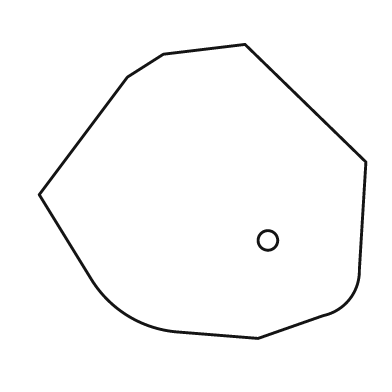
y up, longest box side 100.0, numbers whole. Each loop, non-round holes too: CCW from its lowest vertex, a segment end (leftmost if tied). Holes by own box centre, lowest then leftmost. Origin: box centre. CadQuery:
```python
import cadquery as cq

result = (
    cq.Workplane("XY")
    .moveTo(17.0, -45.0)
    .lineTo(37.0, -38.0)
    .threePointArc((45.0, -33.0), (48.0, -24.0))
    .lineTo(50.0, 9.0)
    .lineTo(13.0, 45.0)
    .lineTo(-12.0, 42.0)
    .lineTo(-23.0, 35.0)
    .lineTo(-50.0, -1.0)
    .lineTo(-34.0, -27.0)
    .threePointArc((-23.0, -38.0), (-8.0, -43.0))
    .close()
    .moveTo(20.0, -15.0)
    .circle(3.0)
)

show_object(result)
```